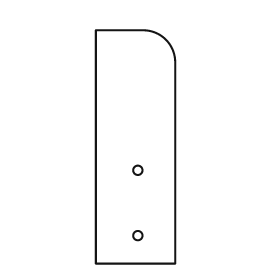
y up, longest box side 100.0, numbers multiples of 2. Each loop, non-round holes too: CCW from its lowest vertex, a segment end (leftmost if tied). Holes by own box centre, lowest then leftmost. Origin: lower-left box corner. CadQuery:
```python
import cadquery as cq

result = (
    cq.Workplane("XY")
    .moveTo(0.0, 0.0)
    .lineTo(34.0, 0.0)
    .lineTo(34.0, 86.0)
    .threePointArc((30.0, 96.0), (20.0, 100.0))
    .lineTo(0.0, 100.0)
    .close()
    .moveTo(18.0, 12.0)
    .circle(2.0)
    .moveTo(18.0, 40.0)
    .circle(2.0)
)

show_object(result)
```